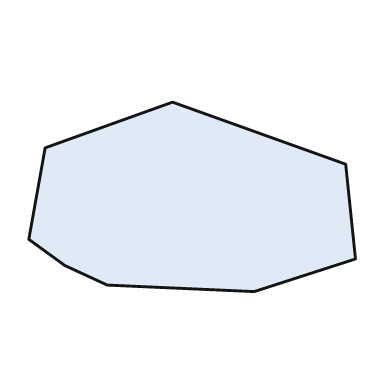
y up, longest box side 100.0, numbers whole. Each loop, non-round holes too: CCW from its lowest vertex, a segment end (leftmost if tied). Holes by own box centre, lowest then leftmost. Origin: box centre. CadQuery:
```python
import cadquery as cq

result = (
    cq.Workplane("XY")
    .moveTo(19.0, -29.0)
    .lineTo(50.0, -19.0)
    .lineTo(47.0, 10.0)
    .lineTo(-6.0, 29.0)
    .lineTo(-45.0, 15.0)
    .lineTo(-50.0, -13.0)
    .lineTo(-39.0, -21.0)
    .lineTo(-26.0, -27.0)
    .close()
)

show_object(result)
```